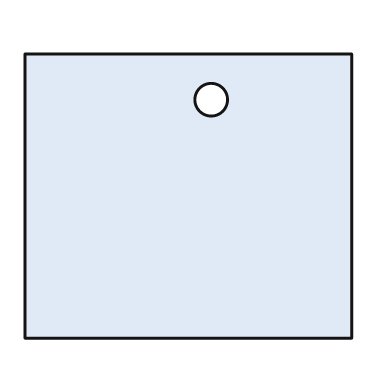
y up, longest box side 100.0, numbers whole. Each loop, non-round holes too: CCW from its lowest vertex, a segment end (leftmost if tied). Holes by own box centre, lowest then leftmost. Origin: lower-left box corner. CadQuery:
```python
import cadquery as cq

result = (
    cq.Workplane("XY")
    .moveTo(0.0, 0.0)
    .lineTo(100.0, 0.0)
    .lineTo(100.0, 87.0)
    .lineTo(0.0, 87.0)
    .close()
    .moveTo(57.0, 73.0)
    .circle(5.0)
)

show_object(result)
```